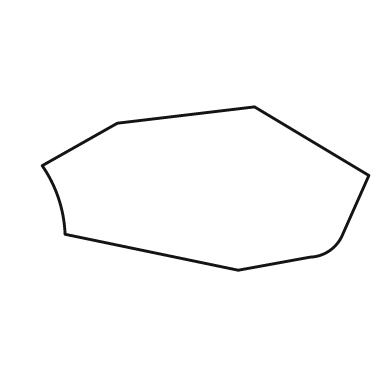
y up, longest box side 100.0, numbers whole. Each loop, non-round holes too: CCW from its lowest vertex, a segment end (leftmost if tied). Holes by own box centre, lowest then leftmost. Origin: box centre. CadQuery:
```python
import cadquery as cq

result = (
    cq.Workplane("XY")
    .moveTo(10.0, -25.0)
    .lineTo(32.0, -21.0)
    .threePointArc((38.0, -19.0), (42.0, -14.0))
    .lineTo(50.0, 4.0)
    .lineTo(15.0, 25.0)
    .lineTo(-27.0, 20.0)
    .lineTo(-50.0, 7.0)
    .threePointArc((-45.0, -3.0), (-43.0, -14.0))
    .close()
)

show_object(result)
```